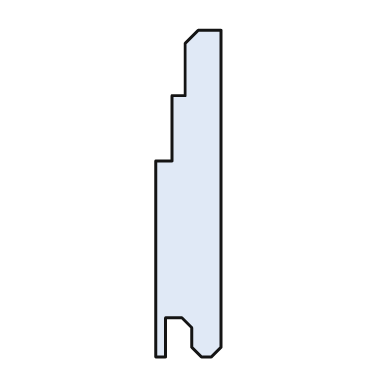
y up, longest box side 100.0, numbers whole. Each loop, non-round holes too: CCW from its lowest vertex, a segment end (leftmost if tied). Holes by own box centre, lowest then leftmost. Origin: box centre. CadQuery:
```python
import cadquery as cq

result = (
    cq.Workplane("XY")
    .moveTo(-10.0, -50.0)
    .lineTo(-7.0, -50.0)
    .lineTo(-7.0, -38.0)
    .lineTo(-2.0, -38.0)
    .lineTo(1.0, -41.0)
    .lineTo(1.0, -47.0)
    .lineTo(4.0, -50.0)
    .lineTo(7.0, -50.0)
    .lineTo(10.0, -47.0)
    .lineTo(10.0, 50.0)
    .lineTo(3.0, 50.0)
    .lineTo(-1.0, 46.0)
    .lineTo(-1.0, 30.0)
    .lineTo(-5.0, 30.0)
    .lineTo(-5.0, 10.0)
    .lineTo(-10.0, 10.0)
    .close()
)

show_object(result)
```